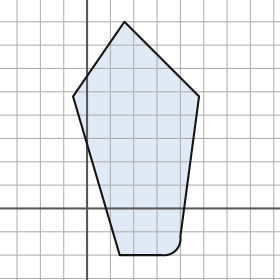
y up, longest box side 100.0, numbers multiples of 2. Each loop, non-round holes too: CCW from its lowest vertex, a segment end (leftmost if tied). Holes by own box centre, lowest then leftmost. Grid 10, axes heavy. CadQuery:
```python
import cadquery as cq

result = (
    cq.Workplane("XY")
    .moveTo(14.0, -20.0)
    .lineTo(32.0, -20.0)
    .threePointArc((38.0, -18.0), (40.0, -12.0))
    .lineTo(48.0, 48.0)
    .lineTo(16.0, 80.0)
    .lineTo(-6.0, 48.0)
    .close()
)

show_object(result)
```